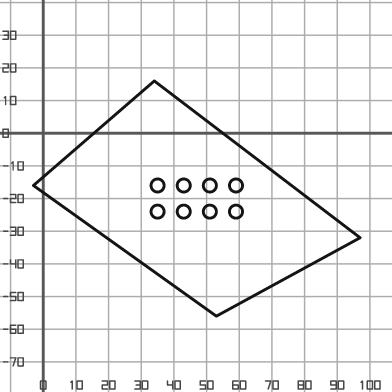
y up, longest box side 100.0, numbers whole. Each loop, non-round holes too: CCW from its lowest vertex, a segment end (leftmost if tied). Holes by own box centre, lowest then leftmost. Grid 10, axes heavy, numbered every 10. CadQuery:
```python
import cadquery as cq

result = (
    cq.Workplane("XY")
    .moveTo(53.0, -56.0)
    .lineTo(97.0, -32.0)
    .lineTo(34.0, 16.0)
    .lineTo(-3.0, -16.0)
    .close()
    .moveTo(35.0, -24.0)
    .circle(2.0)
    .moveTo(43.0, -24.0)
    .circle(2.0)
    .moveTo(51.0, -24.0)
    .circle(2.0)
    .moveTo(59.0, -24.0)
    .circle(2.0)
    .moveTo(35.0, -16.0)
    .circle(2.0)
    .moveTo(43.0, -16.0)
    .circle(2.0)
    .moveTo(51.0, -16.0)
    .circle(2.0)
    .moveTo(59.0, -16.0)
    .circle(2.0)
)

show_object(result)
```